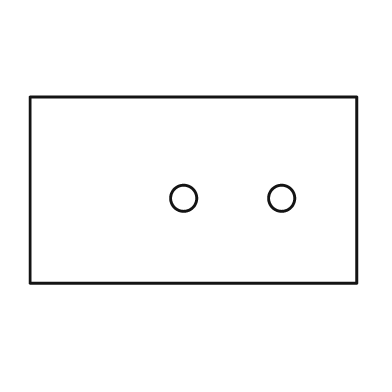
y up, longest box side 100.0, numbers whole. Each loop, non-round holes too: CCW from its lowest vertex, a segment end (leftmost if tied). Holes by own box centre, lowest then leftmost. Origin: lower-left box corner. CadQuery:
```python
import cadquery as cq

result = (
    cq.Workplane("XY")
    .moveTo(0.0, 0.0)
    .lineTo(100.0, 0.0)
    .lineTo(100.0, 57.0)
    .lineTo(0.0, 57.0)
    .close()
    .moveTo(47.0, 26.0)
    .circle(4.0)
    .moveTo(77.0, 26.0)
    .circle(4.0)
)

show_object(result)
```